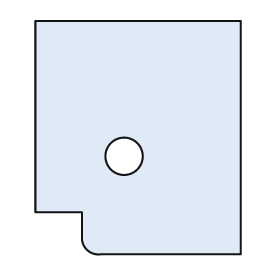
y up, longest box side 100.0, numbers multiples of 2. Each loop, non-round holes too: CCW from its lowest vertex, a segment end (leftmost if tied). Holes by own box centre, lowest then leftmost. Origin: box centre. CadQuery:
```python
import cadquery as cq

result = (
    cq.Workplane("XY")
    .moveTo(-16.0, -50.0)
    .lineTo(44.0, -50.0)
    .lineTo(44.0, 50.0)
    .lineTo(-44.0, 50.0)
    .lineTo(-44.0, -32.0)
    .lineTo(-24.0, -32.0)
    .lineTo(-24.0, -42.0)
    .threePointArc((-22.0, -48.0), (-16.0, -50.0))
    .close()
    .moveTo(-6.0, -8.0)
    .circle(8.0)
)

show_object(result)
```